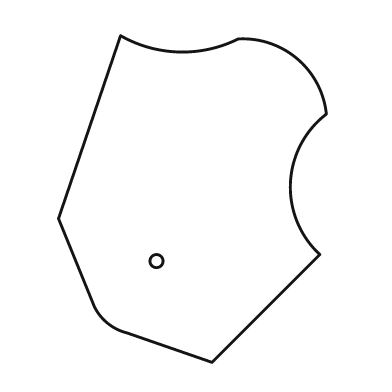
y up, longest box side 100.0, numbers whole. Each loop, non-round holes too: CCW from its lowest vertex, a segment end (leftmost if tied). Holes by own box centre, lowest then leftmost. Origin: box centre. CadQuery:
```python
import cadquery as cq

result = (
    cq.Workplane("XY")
    .moveTo(6.0, -50.0)
    .lineTo(39.0, -17.0)
    .threePointArc((30.0, 5.0), (41.0, 26.0))
    .threePointArc((32.0, 43.0), (14.0, 49.0))
    .threePointArc((-4.0, 45.0), (-22.0, 50.0))
    .lineTo(-41.0, -6.0)
    .lineTo(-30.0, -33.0)
    .threePointArc((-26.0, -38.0), (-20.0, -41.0))
    .close()
    .moveTo(-11.0, -19.0)
    .circle(2.0)
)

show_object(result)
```